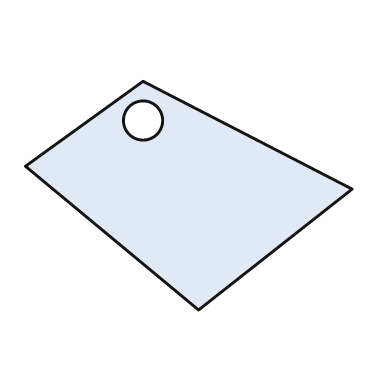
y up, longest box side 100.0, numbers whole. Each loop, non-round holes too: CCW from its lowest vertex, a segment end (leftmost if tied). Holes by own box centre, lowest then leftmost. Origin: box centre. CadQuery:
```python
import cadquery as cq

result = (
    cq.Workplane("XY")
    .moveTo(3.0, -35.0)
    .lineTo(50.0, 2.0)
    .lineTo(-14.0, 35.0)
    .lineTo(-50.0, 9.0)
    .close()
    .moveTo(-14.0, 23.0)
    .circle(6.0)
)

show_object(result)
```